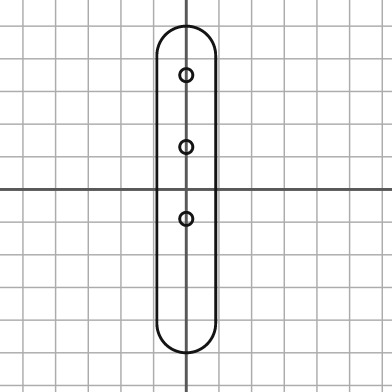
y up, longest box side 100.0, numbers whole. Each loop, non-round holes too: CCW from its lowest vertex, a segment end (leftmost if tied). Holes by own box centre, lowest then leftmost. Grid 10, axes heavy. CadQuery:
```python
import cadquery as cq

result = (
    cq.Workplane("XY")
    .moveTo(-9.0, -41.0)
    .threePointArc((0.0, -50.0), (9.0, -41.0))
    .lineTo(9.0, 41.0)
    .threePointArc((0.0, 50.0), (-9.0, 41.0))
    .close()
    .moveTo(0.0, -9.0)
    .circle(2.0)
    .moveTo(0.0, 13.0)
    .circle(2.0)
    .moveTo(0.0, 35.0)
    .circle(2.0)
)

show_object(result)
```